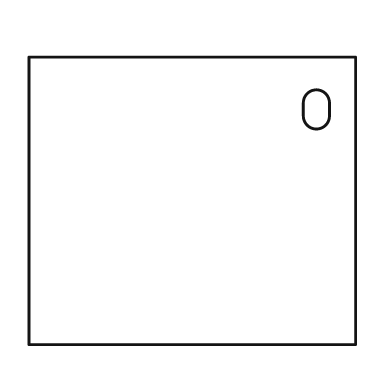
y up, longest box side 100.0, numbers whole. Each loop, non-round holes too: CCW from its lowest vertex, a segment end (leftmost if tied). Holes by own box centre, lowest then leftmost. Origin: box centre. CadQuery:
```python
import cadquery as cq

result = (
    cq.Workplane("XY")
    .moveTo(-50.0, -44.0)
    .lineTo(50.0, -44.0)
    .lineTo(50.0, 44.0)
    .lineTo(-50.0, 44.0)
    .close()
    .moveTo(34.0, 26.0)
    .threePointArc((38.0, 22.0), (42.0, 26.0))
    .lineTo(42.0, 30.0)
    .threePointArc((38.0, 34.0), (34.0, 30.0))
    .close()
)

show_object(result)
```